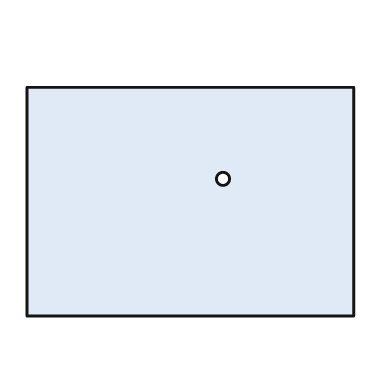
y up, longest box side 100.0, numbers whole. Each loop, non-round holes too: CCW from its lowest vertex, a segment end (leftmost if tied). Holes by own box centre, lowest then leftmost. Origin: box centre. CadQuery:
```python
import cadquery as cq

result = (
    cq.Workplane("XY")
    .moveTo(-50.0, -35.0)
    .lineTo(50.0, -35.0)
    .lineTo(50.0, 35.0)
    .lineTo(-50.0, 35.0)
    .close()
    .moveTo(10.0, 7.0)
    .circle(2.0)
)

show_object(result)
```